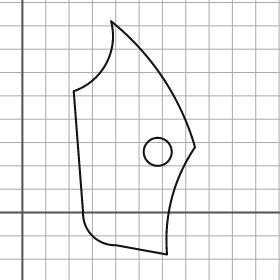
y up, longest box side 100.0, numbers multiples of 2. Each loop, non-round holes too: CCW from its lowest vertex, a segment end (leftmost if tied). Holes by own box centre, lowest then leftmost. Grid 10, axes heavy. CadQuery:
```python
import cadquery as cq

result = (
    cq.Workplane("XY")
    .moveTo(62.0, -18.0)
    .threePointArc((64.0, 6.0), (74.0, 28.0))
    .threePointArc((60.0, 58.0), (38.0, 82.0))
    .threePointArc((36.0, 64.0), (22.0, 52.0))
    .lineTo(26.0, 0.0)
    .threePointArc((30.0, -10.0), (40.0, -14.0))
    .close()
    .moveTo(58.0, 26.0)
    .circle(6.0)
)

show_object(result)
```